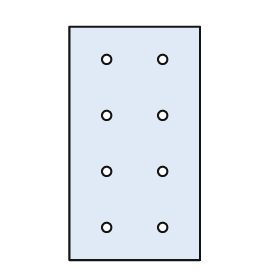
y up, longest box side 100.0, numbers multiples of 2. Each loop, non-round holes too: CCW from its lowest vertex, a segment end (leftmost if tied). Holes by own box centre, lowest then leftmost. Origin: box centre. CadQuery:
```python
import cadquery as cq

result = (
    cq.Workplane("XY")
    .moveTo(-28.0, -50.0)
    .lineTo(28.0, -50.0)
    .lineTo(28.0, 50.0)
    .lineTo(-28.0, 50.0)
    .close()
    .moveTo(-12.0, -36.0)
    .circle(2.0)
    .moveTo(12.0, -36.0)
    .circle(2.0)
    .moveTo(-12.0, -12.0)
    .circle(2.0)
    .moveTo(12.0, -12.0)
    .circle(2.0)
    .moveTo(-12.0, 12.0)
    .circle(2.0)
    .moveTo(12.0, 12.0)
    .circle(2.0)
    .moveTo(-12.0, 36.0)
    .circle(2.0)
    .moveTo(12.0, 36.0)
    .circle(2.0)
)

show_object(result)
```